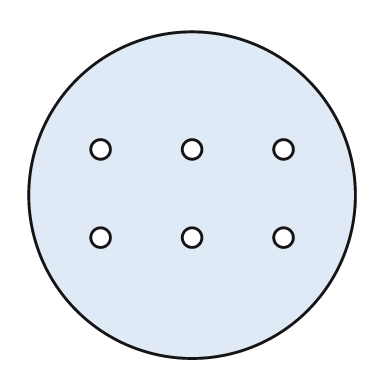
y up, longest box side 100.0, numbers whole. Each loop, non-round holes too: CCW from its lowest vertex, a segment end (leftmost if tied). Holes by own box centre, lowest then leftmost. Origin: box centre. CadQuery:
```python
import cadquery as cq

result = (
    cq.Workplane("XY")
    .moveTo(0.0, 0.0)
    .circle(50.0)
    .moveTo(-28.0, -13.0)
    .circle(3.0)
    .moveTo(0.0, -13.0)
    .circle(3.0)
    .moveTo(28.0, -13.0)
    .circle(3.0)
    .moveTo(-28.0, 14.0)
    .circle(3.0)
    .moveTo(0.0, 14.0)
    .circle(3.0)
    .moveTo(28.0, 14.0)
    .circle(3.0)
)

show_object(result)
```